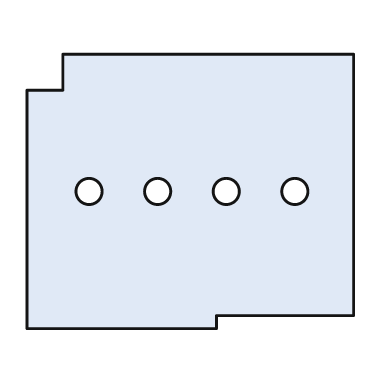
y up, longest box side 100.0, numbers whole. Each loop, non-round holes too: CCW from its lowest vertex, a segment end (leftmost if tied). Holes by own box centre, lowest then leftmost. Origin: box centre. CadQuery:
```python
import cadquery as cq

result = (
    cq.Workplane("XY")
    .moveTo(-50.0, -42.0)
    .lineTo(8.0, -42.0)
    .lineTo(8.0, -38.0)
    .lineTo(50.0, -38.0)
    .lineTo(50.0, 42.0)
    .lineTo(-39.0, 42.0)
    .lineTo(-39.0, 31.0)
    .lineTo(-50.0, 31.0)
    .close()
    .moveTo(-31.0, 0.0)
    .circle(4.0)
    .moveTo(-10.0, 0.0)
    .circle(4.0)
    .moveTo(11.0, 0.0)
    .circle(4.0)
    .moveTo(32.0, 0.0)
    .circle(4.0)
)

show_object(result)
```